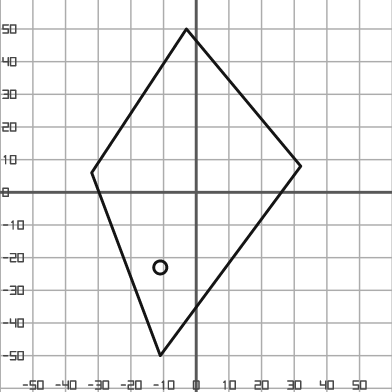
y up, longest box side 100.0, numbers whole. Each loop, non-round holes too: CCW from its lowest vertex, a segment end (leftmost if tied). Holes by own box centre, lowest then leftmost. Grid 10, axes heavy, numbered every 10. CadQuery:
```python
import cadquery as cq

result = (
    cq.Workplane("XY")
    .moveTo(-11.0, -50.0)
    .lineTo(32.0, 8.0)
    .lineTo(-3.0, 50.0)
    .lineTo(-32.0, 6.0)
    .close()
    .moveTo(-11.0, -23.0)
    .circle(2.0)
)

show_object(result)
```